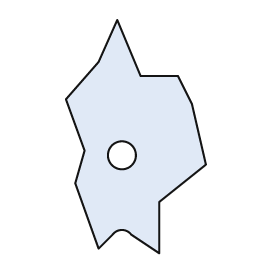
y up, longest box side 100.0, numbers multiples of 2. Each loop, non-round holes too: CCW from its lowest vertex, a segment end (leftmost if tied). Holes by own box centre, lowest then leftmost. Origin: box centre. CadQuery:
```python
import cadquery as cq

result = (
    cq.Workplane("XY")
    .moveTo(10.0, -50.0)
    .lineTo(10.0, -28.0)
    .lineTo(30.0, -12.0)
    .lineTo(24.0, 14.0)
    .lineTo(18.0, 26.0)
    .lineTo(2.0, 26.0)
    .lineTo(-8.0, 50.0)
    .lineTo(-16.0, 32.0)
    .lineTo(-30.0, 16.0)
    .lineTo(-22.0, -6.0)
    .lineTo(-26.0, -20.0)
    .lineTo(-16.0, -48.0)
    .lineTo(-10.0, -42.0)
    .threePointArc((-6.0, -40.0), (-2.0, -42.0))
    .close()
    .moveTo(-6.0, -8.0)
    .circle(6.0)
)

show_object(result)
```